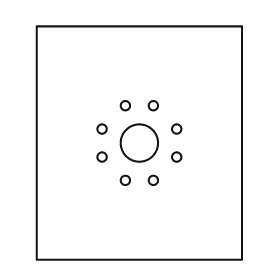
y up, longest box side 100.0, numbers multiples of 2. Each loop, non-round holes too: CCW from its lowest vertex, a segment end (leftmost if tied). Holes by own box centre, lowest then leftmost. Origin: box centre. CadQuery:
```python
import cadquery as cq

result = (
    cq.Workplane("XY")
    .moveTo(-44.0, -50.0)
    .lineTo(44.0, -50.0)
    .lineTo(44.0, 50.0)
    .lineTo(-44.0, 50.0)
    .close()
    .moveTo(-6.0, -16.0)
    .circle(2.0)
    .moveTo(6.0, -16.0)
    .circle(2.0)
    .moveTo(-16.0, -6.0)
    .circle(2.0)
    .moveTo(16.0, -6.0)
    .circle(2.0)
    .moveTo(0.0, 0.0)
    .circle(8.0)
    .moveTo(-16.0, 6.0)
    .circle(2.0)
    .moveTo(16.0, 6.0)
    .circle(2.0)
    .moveTo(-6.0, 16.0)
    .circle(2.0)
    .moveTo(6.0, 16.0)
    .circle(2.0)
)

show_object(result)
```